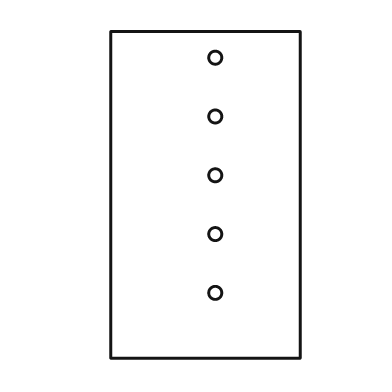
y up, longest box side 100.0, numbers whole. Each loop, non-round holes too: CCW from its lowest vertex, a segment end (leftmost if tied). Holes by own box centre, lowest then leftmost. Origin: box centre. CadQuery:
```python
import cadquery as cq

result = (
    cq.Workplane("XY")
    .moveTo(-29.0, -50.0)
    .lineTo(29.0, -50.0)
    .lineTo(29.0, 50.0)
    .lineTo(-29.0, 50.0)
    .close()
    .moveTo(3.0, -30.0)
    .circle(2.0)
    .moveTo(3.0, -12.0)
    .circle(2.0)
    .moveTo(3.0, 6.0)
    .circle(2.0)
    .moveTo(3.0, 24.0)
    .circle(2.0)
    .moveTo(3.0, 42.0)
    .circle(2.0)
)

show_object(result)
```